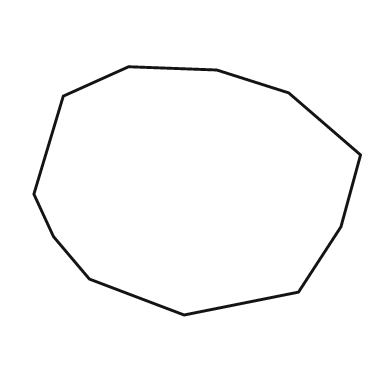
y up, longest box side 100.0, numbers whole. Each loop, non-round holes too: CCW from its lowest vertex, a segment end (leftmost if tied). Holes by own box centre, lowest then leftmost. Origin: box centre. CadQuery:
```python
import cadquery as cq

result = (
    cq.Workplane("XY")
    .moveTo(-4.0, -38.0)
    .lineTo(31.0, -31.0)
    .lineTo(44.0, -11.0)
    .lineTo(50.0, 11.0)
    .lineTo(28.0, 30.0)
    .lineTo(6.0, 37.0)
    .lineTo(-21.0, 38.0)
    .lineTo(-41.0, 29.0)
    .lineTo(-50.0, -1.0)
    .lineTo(-44.0, -14.0)
    .lineTo(-33.0, -27.0)
    .close()
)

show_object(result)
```